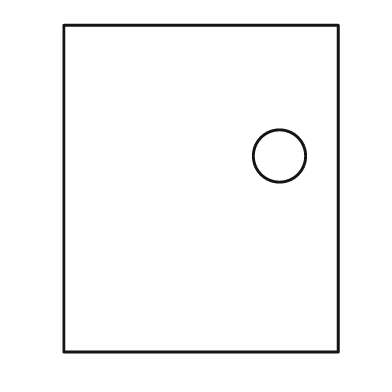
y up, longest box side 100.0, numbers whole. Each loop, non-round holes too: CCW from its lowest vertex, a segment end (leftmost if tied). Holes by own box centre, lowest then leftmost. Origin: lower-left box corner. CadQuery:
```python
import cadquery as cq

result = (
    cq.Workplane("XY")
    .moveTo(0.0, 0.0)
    .lineTo(84.0, 0.0)
    .lineTo(84.0, 100.0)
    .lineTo(0.0, 100.0)
    .close()
    .moveTo(66.0, 60.0)
    .circle(8.0)
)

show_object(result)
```